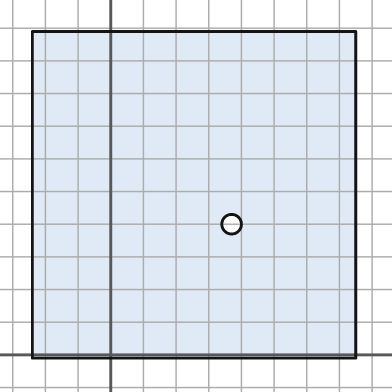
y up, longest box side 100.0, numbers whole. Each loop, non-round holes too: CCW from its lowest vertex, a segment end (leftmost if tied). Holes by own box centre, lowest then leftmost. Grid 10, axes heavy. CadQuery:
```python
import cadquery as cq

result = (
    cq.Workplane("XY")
    .moveTo(-24.0, -1.0)
    .lineTo(75.0, -1.0)
    .lineTo(75.0, 99.0)
    .lineTo(-24.0, 99.0)
    .close()
    .moveTo(37.0, 40.0)
    .circle(3.0)
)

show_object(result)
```